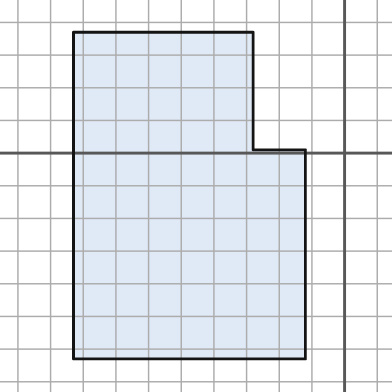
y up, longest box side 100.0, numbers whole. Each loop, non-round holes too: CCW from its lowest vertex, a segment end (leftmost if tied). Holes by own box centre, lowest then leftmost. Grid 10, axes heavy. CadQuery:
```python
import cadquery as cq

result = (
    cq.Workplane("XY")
    .moveTo(-83.0, -63.0)
    .lineTo(-12.0, -63.0)
    .lineTo(-12.0, 1.0)
    .lineTo(-28.0, 1.0)
    .lineTo(-28.0, 37.0)
    .lineTo(-83.0, 37.0)
    .close()
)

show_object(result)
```